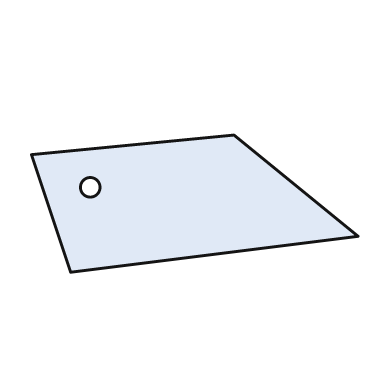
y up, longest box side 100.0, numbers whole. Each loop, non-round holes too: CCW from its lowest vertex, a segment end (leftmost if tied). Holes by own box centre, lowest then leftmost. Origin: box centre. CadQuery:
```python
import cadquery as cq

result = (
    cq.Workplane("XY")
    .moveTo(-38.0, -21.0)
    .lineTo(50.0, -10.0)
    .lineTo(12.0, 21.0)
    .lineTo(-50.0, 15.0)
    .close()
    .moveTo(-32.0, 5.0)
    .circle(3.0)
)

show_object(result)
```